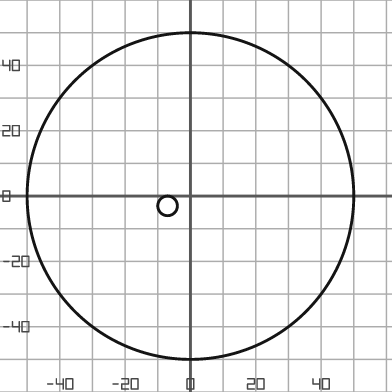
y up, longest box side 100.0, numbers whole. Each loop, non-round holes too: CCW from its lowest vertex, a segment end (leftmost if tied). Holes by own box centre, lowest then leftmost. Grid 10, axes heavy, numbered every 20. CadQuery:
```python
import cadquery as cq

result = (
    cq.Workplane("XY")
    .moveTo(0.0, 0.0)
    .circle(50.0)
    .moveTo(-7.0, -3.0)
    .circle(3.0)
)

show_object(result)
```